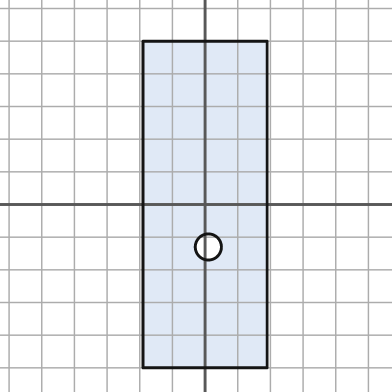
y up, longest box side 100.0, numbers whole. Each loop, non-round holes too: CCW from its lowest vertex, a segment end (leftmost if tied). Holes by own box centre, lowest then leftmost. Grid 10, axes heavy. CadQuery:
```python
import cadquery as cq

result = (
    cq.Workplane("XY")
    .moveTo(-19.0, -50.0)
    .lineTo(19.0, -50.0)
    .lineTo(19.0, 50.0)
    .lineTo(-19.0, 50.0)
    .close()
    .moveTo(1.0, -13.0)
    .circle(4.0)
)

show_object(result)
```